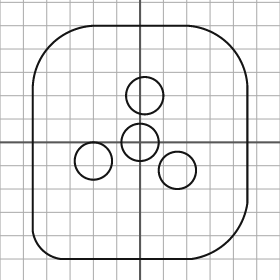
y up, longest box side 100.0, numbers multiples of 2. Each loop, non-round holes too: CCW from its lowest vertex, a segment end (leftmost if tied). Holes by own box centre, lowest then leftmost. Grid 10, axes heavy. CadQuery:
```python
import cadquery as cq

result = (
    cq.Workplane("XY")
    .moveTo(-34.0, -50.0)
    .lineTo(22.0, -50.0)
    .threePointArc((38.0, -42.0), (46.0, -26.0))
    .lineTo(46.0, 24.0)
    .threePointArc((38.0, 42.0), (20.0, 50.0))
    .lineTo(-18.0, 50.0)
    .threePointArc((-38.0, 42.0), (-46.0, 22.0))
    .lineTo(-46.0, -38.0)
    .threePointArc((-42.0, -46.0), (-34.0, -50.0))
    .close()
    .moveTo(16.0, -12.0)
    .circle(8.0)
    .moveTo(-20.0, -8.0)
    .circle(8.0)
    .moveTo(0.0, 0.0)
    .circle(8.0)
    .moveTo(2.0, 20.0)
    .circle(8.0)
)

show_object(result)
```